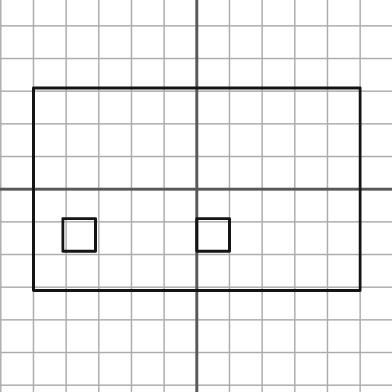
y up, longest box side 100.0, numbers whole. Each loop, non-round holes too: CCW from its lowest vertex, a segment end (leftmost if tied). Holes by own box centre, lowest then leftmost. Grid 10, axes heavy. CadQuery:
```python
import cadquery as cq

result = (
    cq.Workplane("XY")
    .moveTo(-50.0, -31.0)
    .lineTo(50.0, -31.0)
    .lineTo(50.0, 31.0)
    .lineTo(-50.0, 31.0)
    .close()
    .moveTo(-41.0, -19.0)
    .lineTo(-31.0, -19.0)
    .lineTo(-31.0, -9.0)
    .lineTo(-41.0, -9.0)
    .close()
    .moveTo(0.0, -19.0)
    .lineTo(10.0, -19.0)
    .lineTo(10.0, -9.0)
    .lineTo(0.0, -9.0)
    .close()
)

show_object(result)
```